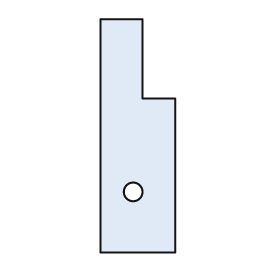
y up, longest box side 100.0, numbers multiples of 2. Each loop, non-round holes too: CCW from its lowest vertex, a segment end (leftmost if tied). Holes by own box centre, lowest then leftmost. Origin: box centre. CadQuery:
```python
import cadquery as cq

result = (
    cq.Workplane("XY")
    .moveTo(-16.0, -50.0)
    .lineTo(16.0, -50.0)
    .lineTo(16.0, 16.0)
    .lineTo(2.0, 16.0)
    .lineTo(2.0, 50.0)
    .lineTo(-16.0, 50.0)
    .close()
    .moveTo(-2.0, -24.0)
    .circle(4.0)
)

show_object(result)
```